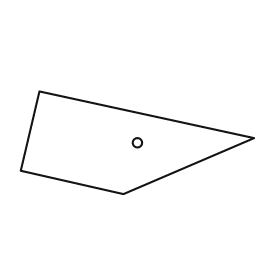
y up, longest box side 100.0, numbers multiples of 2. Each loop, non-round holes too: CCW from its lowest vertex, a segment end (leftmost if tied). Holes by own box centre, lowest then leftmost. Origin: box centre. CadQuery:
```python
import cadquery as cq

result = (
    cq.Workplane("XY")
    .moveTo(-6.0, -22.0)
    .lineTo(50.0, 2.0)
    .lineTo(-42.0, 22.0)
    .lineTo(-50.0, -12.0)
    .close()
    .moveTo(0.0, 0.0)
    .circle(2.0)
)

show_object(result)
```